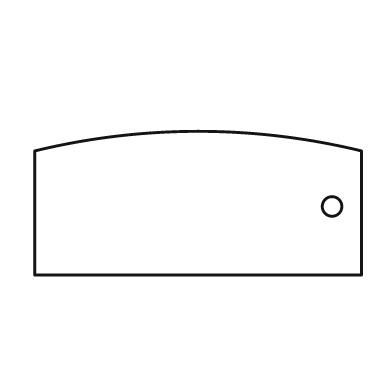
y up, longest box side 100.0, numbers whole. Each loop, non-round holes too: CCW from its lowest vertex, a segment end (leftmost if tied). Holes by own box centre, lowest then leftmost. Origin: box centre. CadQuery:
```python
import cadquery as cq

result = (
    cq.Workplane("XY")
    .moveTo(-50.0, -22.0)
    .lineTo(50.0, -22.0)
    .lineTo(50.0, 16.0)
    .threePointArc((0.0, 22.0), (-50.0, 16.0))
    .close()
    .moveTo(41.0, -1.0)
    .circle(3.0)
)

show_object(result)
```